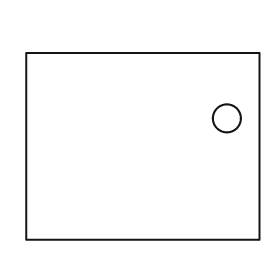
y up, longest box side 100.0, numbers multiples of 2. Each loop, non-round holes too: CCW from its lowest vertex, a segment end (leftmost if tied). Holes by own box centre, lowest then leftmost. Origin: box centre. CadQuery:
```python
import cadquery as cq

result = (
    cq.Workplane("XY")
    .moveTo(-50.0, -40.0)
    .lineTo(50.0, -40.0)
    .lineTo(50.0, 40.0)
    .lineTo(-50.0, 40.0)
    .close()
    .moveTo(36.0, 12.0)
    .circle(6.0)
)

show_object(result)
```